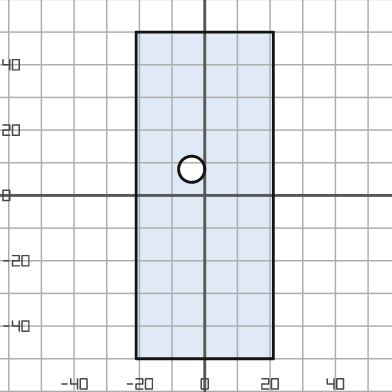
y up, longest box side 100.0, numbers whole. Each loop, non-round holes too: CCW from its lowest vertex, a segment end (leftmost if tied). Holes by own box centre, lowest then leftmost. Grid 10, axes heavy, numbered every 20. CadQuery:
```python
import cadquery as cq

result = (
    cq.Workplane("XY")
    .moveTo(-21.0, -50.0)
    .lineTo(21.0, -50.0)
    .lineTo(21.0, 50.0)
    .lineTo(-21.0, 50.0)
    .close()
    .moveTo(-4.0, 8.0)
    .circle(4.0)
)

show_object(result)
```